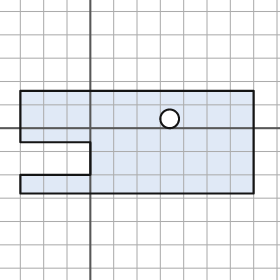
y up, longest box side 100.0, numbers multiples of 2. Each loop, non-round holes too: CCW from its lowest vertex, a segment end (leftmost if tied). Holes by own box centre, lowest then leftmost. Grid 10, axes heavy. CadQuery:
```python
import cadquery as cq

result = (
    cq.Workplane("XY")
    .moveTo(-30.0, -28.0)
    .lineTo(70.0, -28.0)
    .lineTo(70.0, 16.0)
    .lineTo(-30.0, 16.0)
    .lineTo(-30.0, -6.0)
    .lineTo(0.0, -6.0)
    .lineTo(0.0, -20.0)
    .lineTo(-30.0, -20.0)
    .close()
    .moveTo(34.0, 4.0)
    .circle(4.0)
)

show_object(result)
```